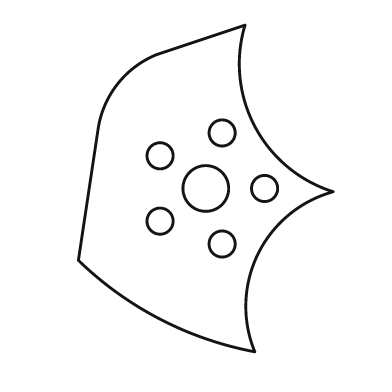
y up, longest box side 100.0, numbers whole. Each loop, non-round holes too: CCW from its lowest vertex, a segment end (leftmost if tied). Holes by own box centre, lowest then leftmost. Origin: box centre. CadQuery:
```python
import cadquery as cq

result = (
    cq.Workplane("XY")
    .moveTo(15.0, -50.0)
    .threePointArc((16.0, -20.0), (39.0, -1.0))
    .threePointArc((15.0, 19.0), (12.0, 50.0))
    .lineTo(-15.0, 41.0)
    .threePointArc((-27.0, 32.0), (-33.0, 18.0))
    .lineTo(-39.0, -22.0)
    .threePointArc((-14.0, -40.0), (15.0, -50.0))
    .close()
    .moveTo(5.0, -17.0)
    .circle(4.0)
    .moveTo(-14.0, -10.0)
    .circle(4.0)
    .moveTo(0.0, 0.0)
    .circle(7.0)
    .moveTo(18.0, 0.0)
    .circle(4.0)
    .moveTo(-14.0, 10.0)
    .circle(4.0)
    .moveTo(5.0, 17.0)
    .circle(4.0)
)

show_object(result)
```